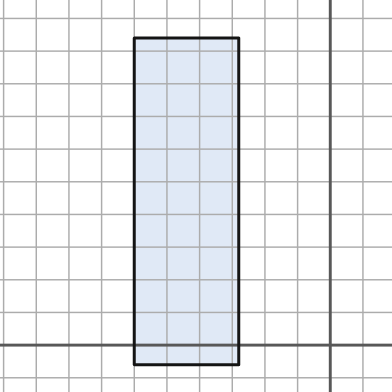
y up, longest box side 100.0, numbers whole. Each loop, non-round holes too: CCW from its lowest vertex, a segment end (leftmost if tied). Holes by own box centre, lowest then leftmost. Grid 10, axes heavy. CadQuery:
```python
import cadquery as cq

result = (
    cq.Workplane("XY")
    .moveTo(-60.0, -6.0)
    .lineTo(-28.0, -6.0)
    .lineTo(-28.0, 94.0)
    .lineTo(-60.0, 94.0)
    .close()
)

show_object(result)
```